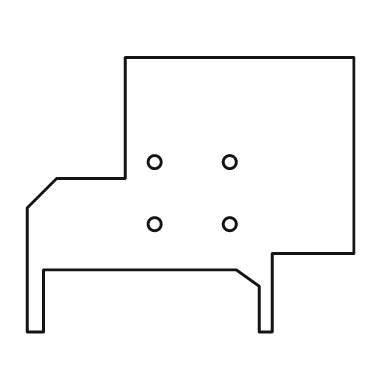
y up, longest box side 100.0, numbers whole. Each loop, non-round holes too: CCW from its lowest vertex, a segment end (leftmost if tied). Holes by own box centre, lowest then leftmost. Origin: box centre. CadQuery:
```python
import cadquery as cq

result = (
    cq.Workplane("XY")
    .moveTo(-50.0, -42.0)
    .lineTo(-45.0, -42.0)
    .lineTo(-45.0, -23.0)
    .lineTo(14.0, -23.0)
    .lineTo(21.0, -28.0)
    .lineTo(21.0, -42.0)
    .lineTo(25.0, -42.0)
    .lineTo(25.0, -18.0)
    .lineTo(50.0, -18.0)
    .lineTo(50.0, 42.0)
    .lineTo(-20.0, 42.0)
    .lineTo(-20.0, 5.0)
    .lineTo(-41.0, 5.0)
    .lineTo(-50.0, -4.0)
    .close()
    .moveTo(-11.0, -9.0)
    .circle(2.0)
    .moveTo(12.0, -9.0)
    .circle(2.0)
    .moveTo(-11.0, 10.0)
    .circle(2.0)
    .moveTo(12.0, 10.0)
    .circle(2.0)
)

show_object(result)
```